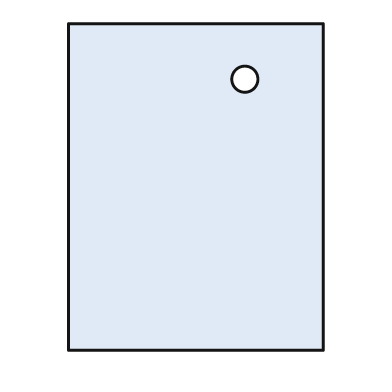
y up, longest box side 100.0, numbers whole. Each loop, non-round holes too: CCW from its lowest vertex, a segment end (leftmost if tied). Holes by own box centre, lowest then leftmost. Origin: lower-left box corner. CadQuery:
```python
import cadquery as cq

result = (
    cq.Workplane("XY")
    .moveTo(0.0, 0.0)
    .lineTo(78.0, 0.0)
    .lineTo(78.0, 100.0)
    .lineTo(0.0, 100.0)
    .close()
    .moveTo(54.0, 83.0)
    .circle(4.0)
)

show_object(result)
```